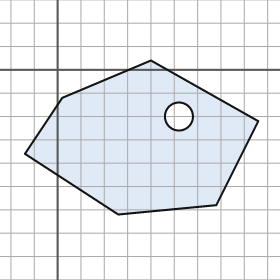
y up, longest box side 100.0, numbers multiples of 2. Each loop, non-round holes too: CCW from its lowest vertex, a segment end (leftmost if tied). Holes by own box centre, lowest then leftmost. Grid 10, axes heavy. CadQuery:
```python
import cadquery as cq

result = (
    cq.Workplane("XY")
    .moveTo(26.0, -62.0)
    .lineTo(68.0, -58.0)
    .lineTo(86.0, -22.0)
    .lineTo(40.0, 4.0)
    .lineTo(2.0, -12.0)
    .lineTo(-14.0, -36.0)
    .close()
    .moveTo(52.0, -20.0)
    .circle(6.0)
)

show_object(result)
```